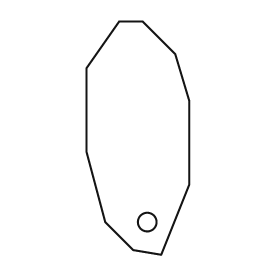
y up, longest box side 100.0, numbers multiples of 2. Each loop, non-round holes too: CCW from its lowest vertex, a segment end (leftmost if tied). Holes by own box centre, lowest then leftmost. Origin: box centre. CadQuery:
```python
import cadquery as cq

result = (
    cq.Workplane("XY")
    .moveTo(10.0, -50.0)
    .lineTo(22.0, -20.0)
    .lineTo(22.0, 16.0)
    .lineTo(16.0, 36.0)
    .lineTo(2.0, 50.0)
    .lineTo(-8.0, 50.0)
    .lineTo(-22.0, 30.0)
    .lineTo(-22.0, -6.0)
    .lineTo(-14.0, -36.0)
    .lineTo(-2.0, -48.0)
    .close()
    .moveTo(4.0, -36.0)
    .circle(4.0)
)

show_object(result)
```